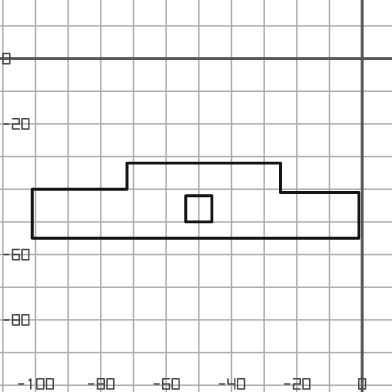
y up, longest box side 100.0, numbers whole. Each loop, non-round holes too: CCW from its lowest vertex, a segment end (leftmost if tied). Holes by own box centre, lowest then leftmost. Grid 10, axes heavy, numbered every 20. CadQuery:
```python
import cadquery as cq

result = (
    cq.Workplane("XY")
    .moveTo(-101.0, -55.0)
    .lineTo(-1.0, -55.0)
    .lineTo(-1.0, -41.0)
    .lineTo(-25.0, -41.0)
    .lineTo(-25.0, -32.0)
    .lineTo(-72.0, -32.0)
    .lineTo(-72.0, -40.0)
    .lineTo(-101.0, -40.0)
    .close()
    .moveTo(-54.0, -50.0)
    .lineTo(-46.0, -50.0)
    .lineTo(-46.0, -42.0)
    .lineTo(-54.0, -42.0)
    .close()
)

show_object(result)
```